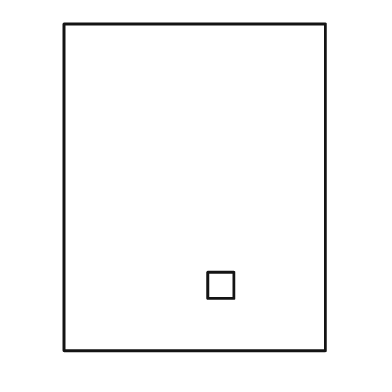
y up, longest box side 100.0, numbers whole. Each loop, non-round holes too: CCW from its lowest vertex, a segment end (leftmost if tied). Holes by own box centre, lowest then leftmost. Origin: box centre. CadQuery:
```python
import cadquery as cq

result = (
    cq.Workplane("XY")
    .moveTo(-40.0, -50.0)
    .lineTo(40.0, -50.0)
    .lineTo(40.0, 50.0)
    .lineTo(-40.0, 50.0)
    .close()
    .moveTo(4.0, -34.0)
    .lineTo(12.0, -34.0)
    .lineTo(12.0, -26.0)
    .lineTo(4.0, -26.0)
    .close()
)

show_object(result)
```